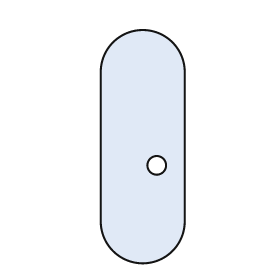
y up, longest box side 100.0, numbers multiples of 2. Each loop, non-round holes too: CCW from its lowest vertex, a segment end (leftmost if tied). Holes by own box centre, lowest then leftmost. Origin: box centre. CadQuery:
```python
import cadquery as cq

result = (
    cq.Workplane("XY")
    .moveTo(-18.0, -32.0)
    .threePointArc((0.0, -50.0), (18.0, -32.0))
    .lineTo(18.0, 32.0)
    .threePointArc((0.0, 50.0), (-18.0, 32.0))
    .close()
    .moveTo(6.0, -8.0)
    .circle(4.0)
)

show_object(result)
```